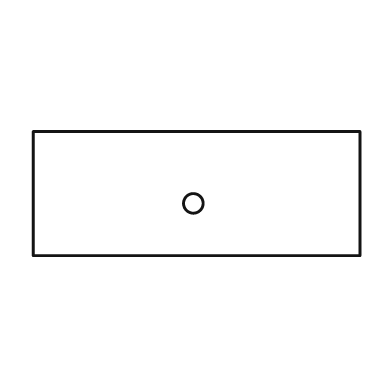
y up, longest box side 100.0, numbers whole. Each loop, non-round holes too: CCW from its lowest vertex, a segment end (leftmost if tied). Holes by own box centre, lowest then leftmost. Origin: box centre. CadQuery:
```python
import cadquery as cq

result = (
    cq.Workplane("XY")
    .moveTo(-50.0, -19.0)
    .lineTo(50.0, -19.0)
    .lineTo(50.0, 19.0)
    .lineTo(-50.0, 19.0)
    .close()
    .moveTo(-1.0, -3.0)
    .circle(3.0)
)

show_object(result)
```